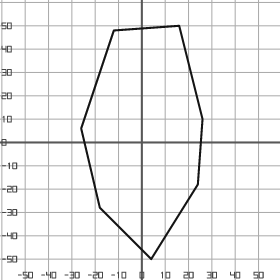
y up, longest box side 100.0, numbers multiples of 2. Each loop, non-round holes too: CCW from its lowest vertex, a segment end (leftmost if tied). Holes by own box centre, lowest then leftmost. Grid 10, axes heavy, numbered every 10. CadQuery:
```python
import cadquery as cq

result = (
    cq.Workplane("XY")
    .moveTo(4.0, -50.0)
    .lineTo(24.0, -18.0)
    .lineTo(26.0, 10.0)
    .lineTo(16.0, 50.0)
    .lineTo(-12.0, 48.0)
    .lineTo(-26.0, 6.0)
    .lineTo(-18.0, -28.0)
    .close()
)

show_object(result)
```